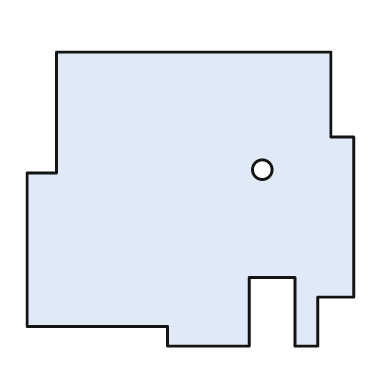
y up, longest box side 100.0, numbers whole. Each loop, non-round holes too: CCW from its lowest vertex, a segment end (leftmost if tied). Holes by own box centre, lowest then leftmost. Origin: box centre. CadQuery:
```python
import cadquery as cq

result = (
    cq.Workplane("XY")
    .moveTo(-7.0, -45.0)
    .lineTo(18.0, -45.0)
    .lineTo(18.0, -24.0)
    .lineTo(32.0, -24.0)
    .lineTo(32.0, -45.0)
    .lineTo(39.0, -45.0)
    .lineTo(39.0, -30.0)
    .lineTo(50.0, -30.0)
    .lineTo(50.0, 19.0)
    .lineTo(43.0, 19.0)
    .lineTo(43.0, 45.0)
    .lineTo(-41.0, 45.0)
    .lineTo(-41.0, 8.0)
    .lineTo(-50.0, 8.0)
    .lineTo(-50.0, -39.0)
    .lineTo(-7.0, -39.0)
    .close()
    .moveTo(22.0, 9.0)
    .circle(3.0)
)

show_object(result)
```